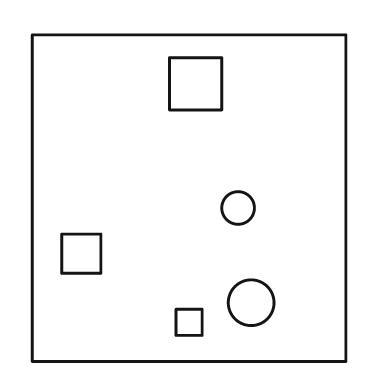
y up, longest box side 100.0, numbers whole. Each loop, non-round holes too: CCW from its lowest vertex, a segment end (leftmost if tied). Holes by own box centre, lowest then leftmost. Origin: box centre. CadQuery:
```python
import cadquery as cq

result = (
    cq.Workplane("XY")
    .moveTo(-48.0, -50.0)
    .lineTo(48.0, -50.0)
    .lineTo(48.0, 50.0)
    .lineTo(-48.0, 50.0)
    .close()
    .moveTo(-4.0, -42.0)
    .lineTo(4.0, -42.0)
    .lineTo(4.0, -34.0)
    .lineTo(-4.0, -34.0)
    .close()
    .moveTo(19.0, -32.0)
    .circle(7.0)
    .moveTo(-39.0, -23.0)
    .lineTo(-27.0, -23.0)
    .lineTo(-27.0, -11.0)
    .lineTo(-39.0, -11.0)
    .close()
    .moveTo(15.0, -3.0)
    .circle(5.0)
    .moveTo(-6.0, 27.0)
    .lineTo(10.0, 27.0)
    .lineTo(10.0, 43.0)
    .lineTo(-6.0, 43.0)
    .close()
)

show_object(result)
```